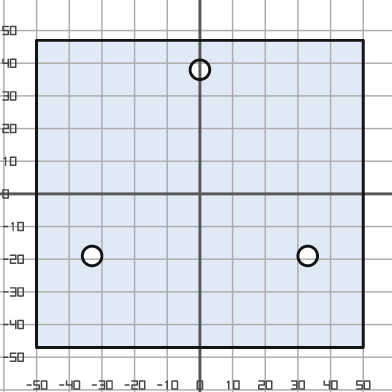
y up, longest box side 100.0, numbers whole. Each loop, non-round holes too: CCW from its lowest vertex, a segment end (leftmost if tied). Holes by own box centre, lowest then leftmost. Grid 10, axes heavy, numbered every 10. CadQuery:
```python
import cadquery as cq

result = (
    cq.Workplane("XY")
    .moveTo(-50.0, -47.0)
    .lineTo(50.0, -47.0)
    .lineTo(50.0, 47.0)
    .lineTo(-50.0, 47.0)
    .close()
    .moveTo(-33.0, -19.0)
    .circle(3.0)
    .moveTo(33.0, -19.0)
    .circle(3.0)
    .moveTo(0.0, 38.0)
    .circle(3.0)
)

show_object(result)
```